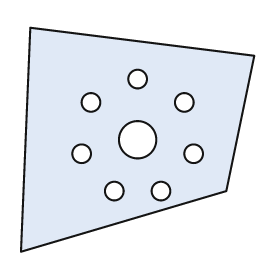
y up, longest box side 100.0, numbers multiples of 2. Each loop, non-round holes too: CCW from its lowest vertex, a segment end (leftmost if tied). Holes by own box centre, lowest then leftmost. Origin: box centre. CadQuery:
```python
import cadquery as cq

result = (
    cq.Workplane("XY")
    .moveTo(-50.0, -48.0)
    .lineTo(38.0, -22.0)
    .lineTo(50.0, 36.0)
    .lineTo(-46.0, 48.0)
    .close()
    .moveTo(-10.0, -22.0)
    .circle(4.0)
    .moveTo(10.0, -22.0)
    .circle(4.0)
    .moveTo(-24.0, -6.0)
    .circle(4.0)
    .moveTo(24.0, -6.0)
    .circle(4.0)
    .moveTo(0.0, 0.0)
    .circle(8.0)
    .moveTo(-20.0, 16.0)
    .circle(4.0)
    .moveTo(20.0, 16.0)
    .circle(4.0)
    .moveTo(0.0, 26.0)
    .circle(4.0)
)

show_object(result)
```